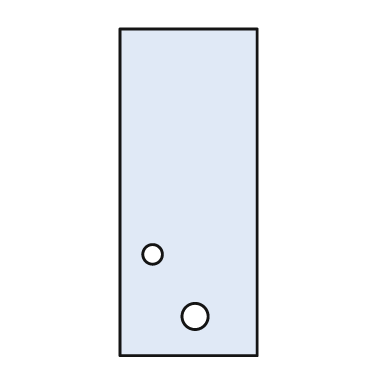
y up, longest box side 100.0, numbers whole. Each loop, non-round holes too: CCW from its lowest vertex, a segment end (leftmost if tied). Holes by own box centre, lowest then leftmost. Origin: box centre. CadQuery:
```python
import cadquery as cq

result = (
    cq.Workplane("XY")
    .moveTo(-21.0, -50.0)
    .lineTo(21.0, -50.0)
    .lineTo(21.0, 50.0)
    .lineTo(-21.0, 50.0)
    .close()
    .moveTo(2.0, -38.0)
    .circle(4.0)
    .moveTo(-11.0, -19.0)
    .circle(3.0)
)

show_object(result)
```